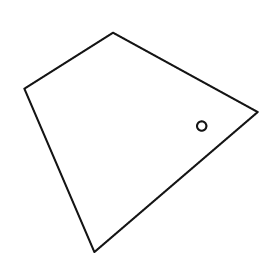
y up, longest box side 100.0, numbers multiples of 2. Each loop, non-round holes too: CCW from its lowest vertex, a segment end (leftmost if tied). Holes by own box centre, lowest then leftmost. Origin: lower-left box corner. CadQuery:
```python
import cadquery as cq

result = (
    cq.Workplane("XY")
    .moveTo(30.0, 0.0)
    .lineTo(100.0, 60.0)
    .lineTo(38.0, 94.0)
    .lineTo(0.0, 70.0)
    .close()
    .moveTo(76.0, 54.0)
    .circle(2.0)
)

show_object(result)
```